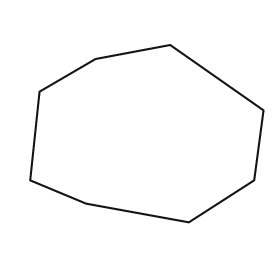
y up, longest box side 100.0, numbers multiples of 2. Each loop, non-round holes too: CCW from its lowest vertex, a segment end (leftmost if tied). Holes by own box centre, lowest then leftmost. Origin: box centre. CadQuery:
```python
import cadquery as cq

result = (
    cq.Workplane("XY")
    .moveTo(18.0, -38.0)
    .lineTo(46.0, -20.0)
    .lineTo(50.0, 10.0)
    .lineTo(10.0, 38.0)
    .lineTo(-22.0, 32.0)
    .lineTo(-46.0, 18.0)
    .lineTo(-50.0, -20.0)
    .lineTo(-26.0, -30.0)
    .close()
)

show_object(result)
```